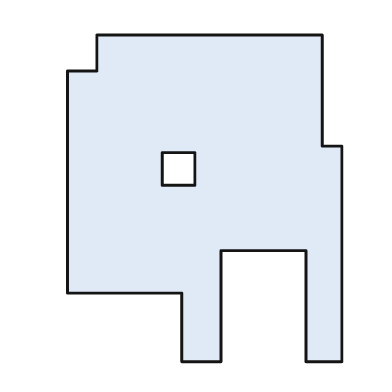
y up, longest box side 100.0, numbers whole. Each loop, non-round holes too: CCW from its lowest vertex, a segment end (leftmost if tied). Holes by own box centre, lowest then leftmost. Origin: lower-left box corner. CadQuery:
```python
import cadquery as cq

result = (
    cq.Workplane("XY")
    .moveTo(35.0, 0.0)
    .lineTo(47.0, 0.0)
    .lineTo(47.0, 34.0)
    .lineTo(73.0, 34.0)
    .lineTo(73.0, 0.0)
    .lineTo(84.0, 0.0)
    .lineTo(84.0, 66.0)
    .lineTo(78.0, 66.0)
    .lineTo(78.0, 100.0)
    .lineTo(9.0, 100.0)
    .lineTo(9.0, 89.0)
    .lineTo(0.0, 89.0)
    .lineTo(0.0, 21.0)
    .lineTo(35.0, 21.0)
    .close()
    .moveTo(29.0, 54.0)
    .lineTo(39.0, 54.0)
    .lineTo(39.0, 64.0)
    .lineTo(29.0, 64.0)
    .close()
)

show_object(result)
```